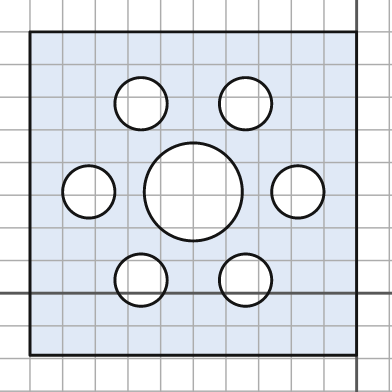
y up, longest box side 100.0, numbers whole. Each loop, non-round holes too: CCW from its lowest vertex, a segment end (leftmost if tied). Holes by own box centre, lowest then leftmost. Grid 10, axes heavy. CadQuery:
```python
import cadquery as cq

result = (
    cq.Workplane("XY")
    .moveTo(-100.0, -19.0)
    .lineTo(0.0, -19.0)
    .lineTo(0.0, 80.0)
    .lineTo(-100.0, 80.0)
    .close()
    .moveTo(-66.0, 4.0)
    .circle(8.0)
    .moveTo(-34.0, 4.0)
    .circle(8.0)
    .moveTo(-82.0, 31.0)
    .circle(8.0)
    .moveTo(-50.0, 31.0)
    .circle(15.0)
    .moveTo(-18.0, 31.0)
    .circle(8.0)
    .moveTo(-66.0, 58.0)
    .circle(8.0)
    .moveTo(-34.0, 58.0)
    .circle(8.0)
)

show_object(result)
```